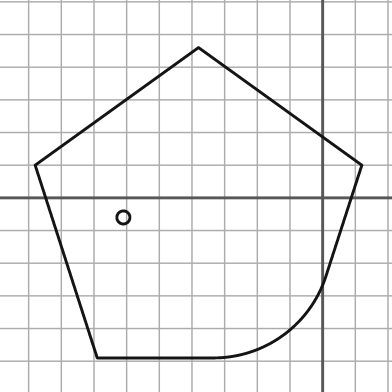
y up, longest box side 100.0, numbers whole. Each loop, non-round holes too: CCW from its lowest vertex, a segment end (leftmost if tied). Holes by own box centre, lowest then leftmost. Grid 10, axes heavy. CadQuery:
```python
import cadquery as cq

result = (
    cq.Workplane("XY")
    .moveTo(-69.0, -49.0)
    .lineTo(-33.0, -49.0)
    .threePointArc((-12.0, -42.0), (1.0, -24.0))
    .lineTo(12.0, 10.0)
    .lineTo(-38.0, 46.0)
    .lineTo(-88.0, 10.0)
    .close()
    .moveTo(-61.0, -6.0)
    .circle(2.0)
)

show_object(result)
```